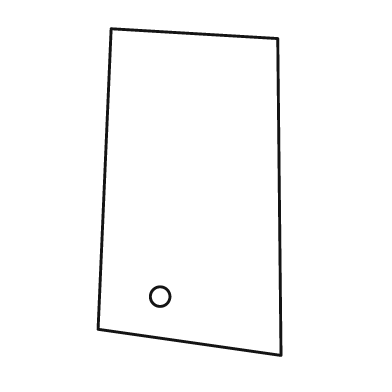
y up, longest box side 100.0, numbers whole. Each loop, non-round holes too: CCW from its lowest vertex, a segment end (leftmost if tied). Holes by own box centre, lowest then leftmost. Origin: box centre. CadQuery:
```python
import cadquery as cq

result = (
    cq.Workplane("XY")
    .moveTo(28.0, -50.0)
    .lineTo(27.0, 47.0)
    .lineTo(-24.0, 50.0)
    .lineTo(-28.0, -42.0)
    .close()
    .moveTo(-9.0, -32.0)
    .circle(3.0)
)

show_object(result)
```